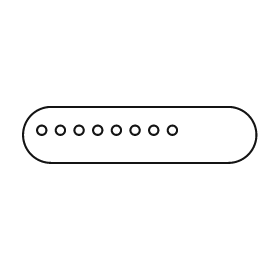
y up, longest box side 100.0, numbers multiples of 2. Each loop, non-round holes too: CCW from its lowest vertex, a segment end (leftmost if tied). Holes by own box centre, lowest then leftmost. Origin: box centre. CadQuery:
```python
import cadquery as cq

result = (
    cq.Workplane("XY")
    .moveTo(-38.0, -12.0)
    .lineTo(38.0, -12.0)
    .threePointArc((50.0, 0.0), (38.0, 12.0))
    .lineTo(-38.0, 12.0)
    .threePointArc((-50.0, 0.0), (-38.0, -12.0))
    .close()
    .moveTo(-42.0, 2.0)
    .circle(2.0)
    .moveTo(-34.0, 2.0)
    .circle(2.0)
    .moveTo(-26.0, 2.0)
    .circle(2.0)
    .moveTo(-18.0, 2.0)
    .circle(2.0)
    .moveTo(-10.0, 2.0)
    .circle(2.0)
    .moveTo(-2.0, 2.0)
    .circle(2.0)
    .moveTo(6.0, 2.0)
    .circle(2.0)
    .moveTo(14.0, 2.0)
    .circle(2.0)
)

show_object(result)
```